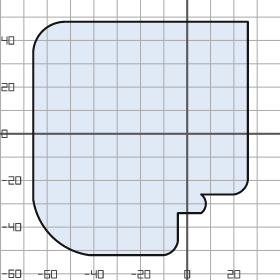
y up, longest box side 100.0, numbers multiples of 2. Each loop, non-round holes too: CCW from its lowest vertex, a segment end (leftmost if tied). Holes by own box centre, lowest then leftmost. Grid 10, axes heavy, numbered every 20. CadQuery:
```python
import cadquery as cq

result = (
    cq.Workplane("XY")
    .moveTo(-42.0, -52.0)
    .lineTo(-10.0, -52.0)
    .threePointArc((-6.0, -50.0), (-4.0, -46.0))
    .lineTo(-4.0, -34.0)
    .lineTo(6.0, -34.0)
    .threePointArc((8.0, -30.0), (6.0, -26.0))
    .lineTo(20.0, -26.0)
    .threePointArc((24.0, -24.0), (26.0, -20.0))
    .lineTo(26.0, 48.0)
    .lineTo(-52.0, 48.0)
    .threePointArc((-62.0, 44.0), (-66.0, 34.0))
    .lineTo(-66.0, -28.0)
    .threePointArc((-58.0, -44.0), (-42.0, -52.0))
    .close()
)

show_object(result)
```